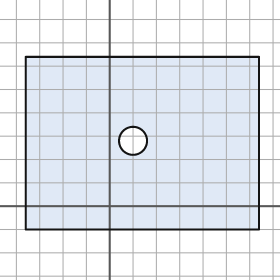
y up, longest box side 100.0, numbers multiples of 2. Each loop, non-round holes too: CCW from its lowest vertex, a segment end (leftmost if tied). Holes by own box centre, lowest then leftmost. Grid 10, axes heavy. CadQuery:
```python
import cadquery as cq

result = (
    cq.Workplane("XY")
    .moveTo(-36.0, -10.0)
    .lineTo(64.0, -10.0)
    .lineTo(64.0, 64.0)
    .lineTo(-36.0, 64.0)
    .close()
    .moveTo(10.0, 28.0)
    .circle(6.0)
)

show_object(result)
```